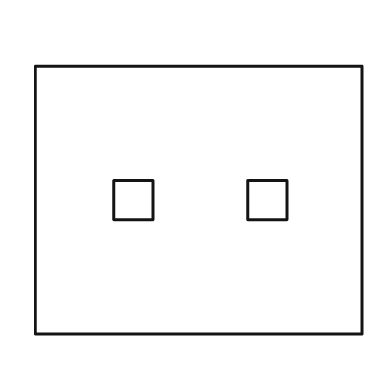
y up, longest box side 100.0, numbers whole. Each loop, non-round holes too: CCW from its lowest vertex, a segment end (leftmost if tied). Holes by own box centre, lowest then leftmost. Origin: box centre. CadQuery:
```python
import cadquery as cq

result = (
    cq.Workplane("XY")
    .moveTo(-50.0, -41.0)
    .lineTo(50.0, -41.0)
    .lineTo(50.0, 41.0)
    .lineTo(-50.0, 41.0)
    .close()
    .moveTo(-26.0, -6.0)
    .lineTo(-14.0, -6.0)
    .lineTo(-14.0, 6.0)
    .lineTo(-26.0, 6.0)
    .close()
    .moveTo(15.0, -6.0)
    .lineTo(27.0, -6.0)
    .lineTo(27.0, 6.0)
    .lineTo(15.0, 6.0)
    .close()
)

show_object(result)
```